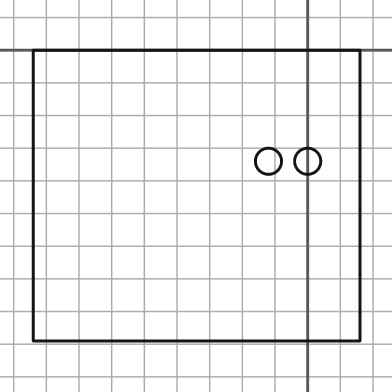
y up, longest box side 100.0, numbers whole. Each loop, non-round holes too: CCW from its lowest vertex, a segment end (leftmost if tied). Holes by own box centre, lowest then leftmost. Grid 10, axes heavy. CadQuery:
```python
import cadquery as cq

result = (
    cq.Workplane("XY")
    .moveTo(-84.0, -89.0)
    .lineTo(16.0, -89.0)
    .lineTo(16.0, 0.0)
    .lineTo(-84.0, 0.0)
    .close()
    .moveTo(-12.0, -34.0)
    .circle(4.0)
    .moveTo(0.0, -34.0)
    .circle(4.0)
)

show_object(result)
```